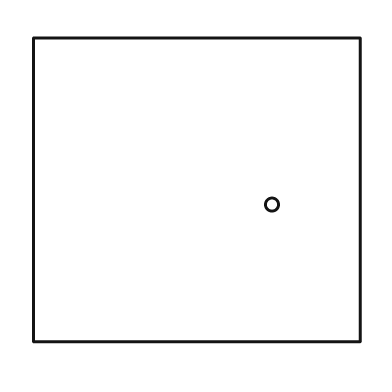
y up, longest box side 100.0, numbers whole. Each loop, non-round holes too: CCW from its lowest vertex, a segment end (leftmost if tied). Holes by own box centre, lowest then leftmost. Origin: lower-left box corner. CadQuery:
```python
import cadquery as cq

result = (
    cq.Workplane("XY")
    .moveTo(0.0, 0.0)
    .lineTo(100.0, 0.0)
    .lineTo(100.0, 93.0)
    .lineTo(0.0, 93.0)
    .close()
    .moveTo(73.0, 42.0)
    .circle(2.0)
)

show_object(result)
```